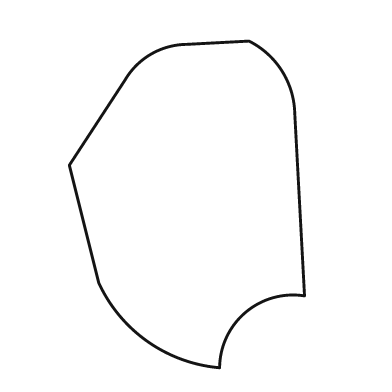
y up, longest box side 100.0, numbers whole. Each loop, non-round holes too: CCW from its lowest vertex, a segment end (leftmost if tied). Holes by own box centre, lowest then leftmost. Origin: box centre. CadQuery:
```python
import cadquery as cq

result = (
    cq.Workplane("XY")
    .moveTo(10.0, -50.0)
    .threePointArc((18.0, -33.0), (36.0, -28.0))
    .lineTo(33.0, 28.0)
    .threePointArc((29.0, 41.0), (19.0, 50.0))
    .lineTo(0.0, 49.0)
    .threePointArc((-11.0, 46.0), (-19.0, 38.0))
    .lineTo(-36.0, 12.0)
    .lineTo(-27.0, -24.0)
    .threePointArc((-12.0, -42.0), (10.0, -50.0))
    .close()
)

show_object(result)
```